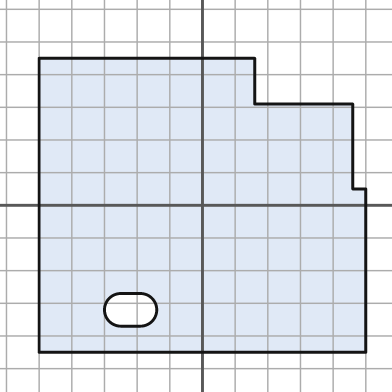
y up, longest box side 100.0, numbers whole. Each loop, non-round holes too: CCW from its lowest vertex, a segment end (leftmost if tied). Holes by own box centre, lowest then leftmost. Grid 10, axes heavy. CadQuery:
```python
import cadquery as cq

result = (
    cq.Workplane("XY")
    .moveTo(-50.0, -45.0)
    .lineTo(50.0, -45.0)
    .lineTo(50.0, 5.0)
    .lineTo(46.0, 5.0)
    .lineTo(46.0, 31.0)
    .lineTo(16.0, 31.0)
    .lineTo(16.0, 45.0)
    .lineTo(-50.0, 45.0)
    .close()
    .moveTo(-25.0, -37.0)
    .lineTo(-19.0, -37.0)
    .threePointArc((-14.0, -32.0), (-19.0, -27.0))
    .lineTo(-25.0, -27.0)
    .threePointArc((-30.0, -32.0), (-25.0, -37.0))
    .close()
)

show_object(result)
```